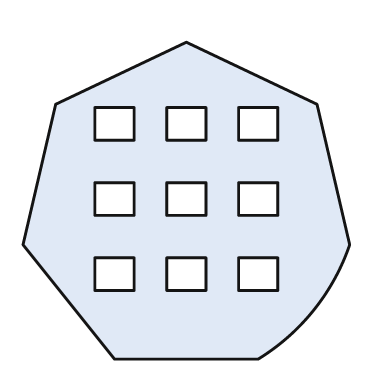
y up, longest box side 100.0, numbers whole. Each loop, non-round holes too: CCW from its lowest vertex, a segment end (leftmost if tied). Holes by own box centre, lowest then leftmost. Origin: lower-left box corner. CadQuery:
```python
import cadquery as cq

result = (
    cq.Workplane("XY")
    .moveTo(28.0, 0.0)
    .lineTo(72.0, 0.0)
    .threePointArc((89.0, 15.0), (100.0, 35.0))
    .lineTo(90.0, 78.0)
    .lineTo(50.0, 97.0)
    .lineTo(10.0, 78.0)
    .lineTo(0.0, 35.0)
    .close()
    .moveTo(22.0, 21.0)
    .lineTo(34.0, 21.0)
    .lineTo(34.0, 31.0)
    .lineTo(22.0, 31.0)
    .close()
    .moveTo(44.0, 21.0)
    .lineTo(56.0, 21.0)
    .lineTo(56.0, 31.0)
    .lineTo(44.0, 31.0)
    .close()
    .moveTo(66.0, 21.0)
    .lineTo(78.0, 21.0)
    .lineTo(78.0, 31.0)
    .lineTo(66.0, 31.0)
    .close()
    .moveTo(22.0, 44.0)
    .lineTo(34.0, 44.0)
    .lineTo(34.0, 54.0)
    .lineTo(22.0, 54.0)
    .close()
    .moveTo(44.0, 44.0)
    .lineTo(56.0, 44.0)
    .lineTo(56.0, 54.0)
    .lineTo(44.0, 54.0)
    .close()
    .moveTo(66.0, 44.0)
    .lineTo(78.0, 44.0)
    .lineTo(78.0, 54.0)
    .lineTo(66.0, 54.0)
    .close()
    .moveTo(22.0, 67.0)
    .lineTo(34.0, 67.0)
    .lineTo(34.0, 77.0)
    .lineTo(22.0, 77.0)
    .close()
    .moveTo(44.0, 67.0)
    .lineTo(56.0, 67.0)
    .lineTo(56.0, 77.0)
    .lineTo(44.0, 77.0)
    .close()
    .moveTo(66.0, 67.0)
    .lineTo(78.0, 67.0)
    .lineTo(78.0, 77.0)
    .lineTo(66.0, 77.0)
    .close()
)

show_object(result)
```